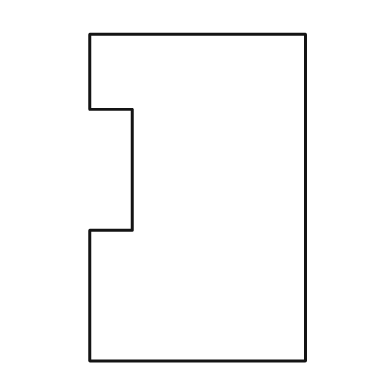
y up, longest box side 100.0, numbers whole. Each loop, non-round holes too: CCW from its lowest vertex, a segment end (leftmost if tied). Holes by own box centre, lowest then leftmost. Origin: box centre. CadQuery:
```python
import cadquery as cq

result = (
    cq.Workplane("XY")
    .moveTo(-33.0, -50.0)
    .lineTo(33.0, -50.0)
    .lineTo(33.0, 50.0)
    .lineTo(-33.0, 50.0)
    .lineTo(-33.0, 27.0)
    .lineTo(-20.0, 27.0)
    .lineTo(-20.0, -10.0)
    .lineTo(-33.0, -10.0)
    .close()
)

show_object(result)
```